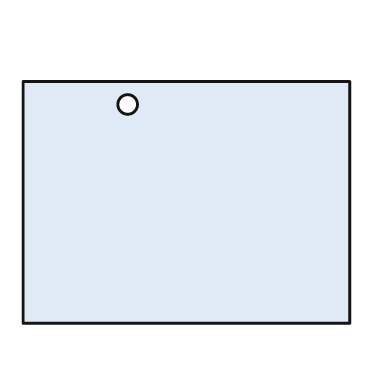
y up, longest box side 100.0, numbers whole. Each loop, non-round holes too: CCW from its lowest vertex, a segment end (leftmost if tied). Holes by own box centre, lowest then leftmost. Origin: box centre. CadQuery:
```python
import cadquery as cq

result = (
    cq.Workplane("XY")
    .moveTo(-50.0, -37.0)
    .lineTo(50.0, -37.0)
    .lineTo(50.0, 37.0)
    .lineTo(-50.0, 37.0)
    .close()
    .moveTo(-18.0, 30.0)
    .circle(3.0)
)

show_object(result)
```